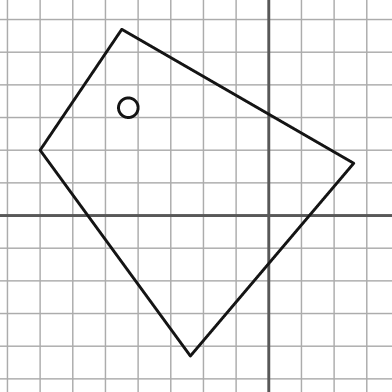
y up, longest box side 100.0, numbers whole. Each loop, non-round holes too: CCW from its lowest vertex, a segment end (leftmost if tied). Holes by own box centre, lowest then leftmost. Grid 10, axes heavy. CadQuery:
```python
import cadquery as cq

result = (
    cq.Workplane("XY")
    .moveTo(-24.0, -43.0)
    .lineTo(26.0, 16.0)
    .lineTo(-45.0, 57.0)
    .lineTo(-70.0, 20.0)
    .close()
    .moveTo(-43.0, 33.0)
    .circle(3.0)
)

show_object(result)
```